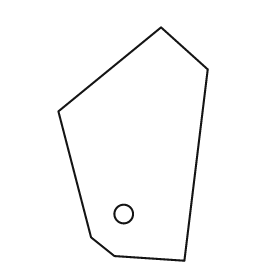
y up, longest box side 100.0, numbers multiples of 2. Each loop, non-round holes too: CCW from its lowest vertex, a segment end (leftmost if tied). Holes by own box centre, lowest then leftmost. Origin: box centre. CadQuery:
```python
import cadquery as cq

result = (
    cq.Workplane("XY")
    .moveTo(22.0, -50.0)
    .lineTo(32.0, 32.0)
    .lineTo(12.0, 50.0)
    .lineTo(-32.0, 14.0)
    .lineTo(-18.0, -40.0)
    .lineTo(-8.0, -48.0)
    .close()
    .moveTo(-4.0, -30.0)
    .circle(4.0)
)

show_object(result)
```